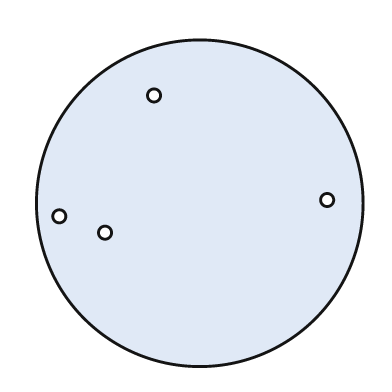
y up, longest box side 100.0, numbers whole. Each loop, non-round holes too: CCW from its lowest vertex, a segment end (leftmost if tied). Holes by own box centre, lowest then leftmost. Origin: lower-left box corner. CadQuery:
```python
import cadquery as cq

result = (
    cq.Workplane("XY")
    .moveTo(50.0, 50.0)
    .circle(50.0)
    .moveTo(21.0, 41.0)
    .circle(2.0)
    .moveTo(7.0, 46.0)
    .circle(2.0)
    .moveTo(89.0, 51.0)
    .circle(2.0)
    .moveTo(36.0, 83.0)
    .circle(2.0)
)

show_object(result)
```